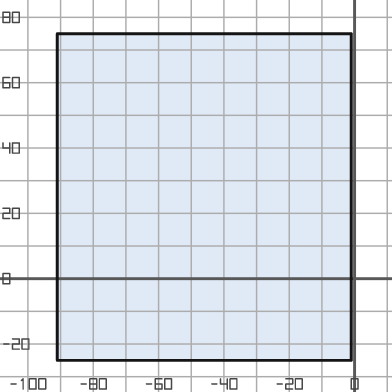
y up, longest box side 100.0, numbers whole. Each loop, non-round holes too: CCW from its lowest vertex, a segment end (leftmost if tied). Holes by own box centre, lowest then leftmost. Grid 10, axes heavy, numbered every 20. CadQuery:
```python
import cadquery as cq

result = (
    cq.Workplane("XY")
    .moveTo(-91.0, -25.0)
    .lineTo(-1.0, -25.0)
    .lineTo(-1.0, 75.0)
    .lineTo(-91.0, 75.0)
    .close()
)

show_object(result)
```